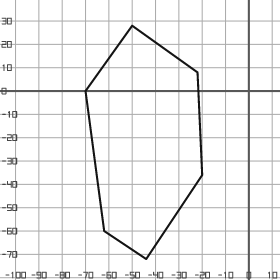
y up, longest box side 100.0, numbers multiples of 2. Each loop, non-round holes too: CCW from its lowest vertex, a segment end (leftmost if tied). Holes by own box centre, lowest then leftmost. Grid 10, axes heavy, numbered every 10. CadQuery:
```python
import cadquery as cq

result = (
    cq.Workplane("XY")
    .moveTo(-44.0, -72.0)
    .lineTo(-20.0, -36.0)
    .lineTo(-22.0, 8.0)
    .lineTo(-50.0, 28.0)
    .lineTo(-70.0, 0.0)
    .lineTo(-62.0, -60.0)
    .close()
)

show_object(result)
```